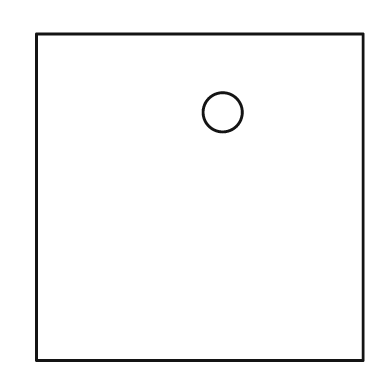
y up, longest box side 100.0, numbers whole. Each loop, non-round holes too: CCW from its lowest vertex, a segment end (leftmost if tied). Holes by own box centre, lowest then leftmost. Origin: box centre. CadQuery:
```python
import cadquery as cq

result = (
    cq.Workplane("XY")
    .moveTo(-50.0, -50.0)
    .lineTo(50.0, -50.0)
    .lineTo(50.0, 50.0)
    .lineTo(-50.0, 50.0)
    .close()
    .moveTo(7.0, 26.0)
    .circle(6.0)
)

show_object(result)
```